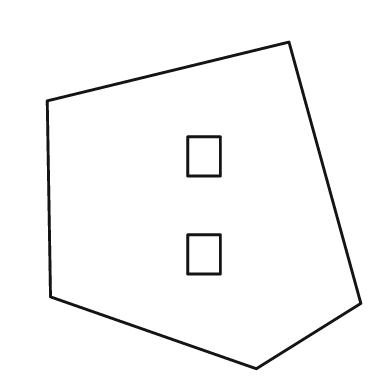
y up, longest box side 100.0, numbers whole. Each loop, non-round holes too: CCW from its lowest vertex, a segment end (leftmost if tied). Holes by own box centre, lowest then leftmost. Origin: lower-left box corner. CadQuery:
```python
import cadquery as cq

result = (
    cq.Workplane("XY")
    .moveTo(64.0, 0.0)
    .lineTo(96.0, 20.0)
    .lineTo(74.0, 100.0)
    .lineTo(0.0, 82.0)
    .lineTo(1.0, 22.0)
    .close()
    .moveTo(43.0, 29.0)
    .lineTo(53.0, 29.0)
    .lineTo(53.0, 41.0)
    .lineTo(43.0, 41.0)
    .close()
    .moveTo(43.0, 59.0)
    .lineTo(53.0, 59.0)
    .lineTo(53.0, 71.0)
    .lineTo(43.0, 71.0)
    .close()
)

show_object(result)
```